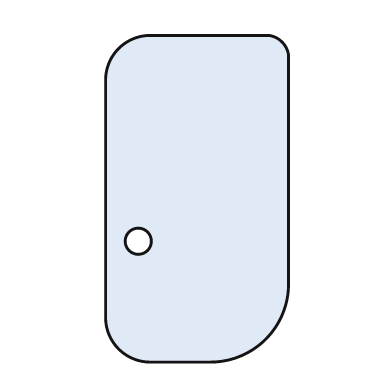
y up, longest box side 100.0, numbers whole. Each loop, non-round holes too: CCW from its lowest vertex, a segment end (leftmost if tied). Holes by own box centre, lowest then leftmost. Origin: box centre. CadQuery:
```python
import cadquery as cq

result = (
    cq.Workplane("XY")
    .moveTo(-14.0, -50.0)
    .lineTo(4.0, -50.0)
    .threePointArc((21.0, -43.0), (28.0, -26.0))
    .lineTo(28.0, 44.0)
    .threePointArc((26.0, 48.0), (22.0, 50.0))
    .lineTo(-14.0, 50.0)
    .threePointArc((-24.0, 46.0), (-28.0, 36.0))
    .lineTo(-28.0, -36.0)
    .threePointArc((-24.0, -46.0), (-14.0, -50.0))
    .close()
    .moveTo(-18.0, -13.0)
    .circle(4.0)
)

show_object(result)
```